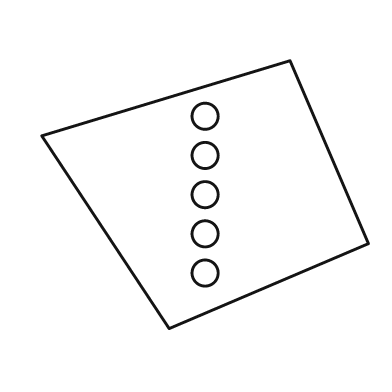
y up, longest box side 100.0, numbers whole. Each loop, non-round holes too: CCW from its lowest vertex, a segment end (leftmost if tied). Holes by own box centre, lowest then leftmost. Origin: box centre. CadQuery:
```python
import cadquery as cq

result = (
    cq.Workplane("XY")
    .moveTo(-11.0, -41.0)
    .lineTo(50.0, -15.0)
    .lineTo(26.0, 41.0)
    .lineTo(-50.0, 18.0)
    .close()
    .moveTo(0.0, -24.0)
    .circle(4.0)
    .moveTo(0.0, -12.0)
    .circle(4.0)
    .moveTo(0.0, 0.0)
    .circle(4.0)
    .moveTo(0.0, 12.0)
    .circle(4.0)
    .moveTo(0.0, 24.0)
    .circle(4.0)
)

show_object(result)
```